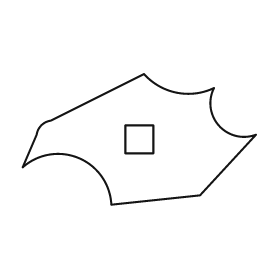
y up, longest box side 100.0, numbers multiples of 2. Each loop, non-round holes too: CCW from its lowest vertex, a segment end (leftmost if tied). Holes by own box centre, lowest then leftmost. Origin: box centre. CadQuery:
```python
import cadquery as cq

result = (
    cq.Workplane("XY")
    .moveTo(-12.0, -28.0)
    .lineTo(26.0, -24.0)
    .lineTo(50.0, 2.0)
    .threePointArc((34.0, 6.0), (32.0, 22.0))
    .threePointArc((16.0, 20.0), (2.0, 28.0))
    .lineTo(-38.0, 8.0)
    .threePointArc((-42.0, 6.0), (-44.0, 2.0))
    .lineTo(-50.0, -12.0)
    .threePointArc((-26.0, -8.0), (-12.0, -28.0))
    .close()
    .moveTo(-6.0, -6.0)
    .lineTo(6.0, -6.0)
    .lineTo(6.0, 6.0)
    .lineTo(-6.0, 6.0)
    .close()
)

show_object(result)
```